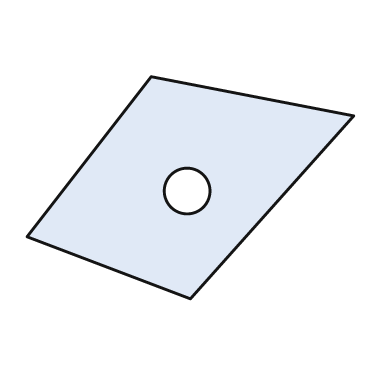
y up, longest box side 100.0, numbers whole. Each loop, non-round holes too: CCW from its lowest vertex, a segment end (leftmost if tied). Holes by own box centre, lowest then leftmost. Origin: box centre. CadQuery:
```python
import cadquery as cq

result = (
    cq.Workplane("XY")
    .moveTo(0.0, -34.0)
    .lineTo(50.0, 22.0)
    .lineTo(-12.0, 34.0)
    .lineTo(-50.0, -15.0)
    .close()
    .moveTo(-1.0, -1.0)
    .circle(7.0)
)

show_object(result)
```